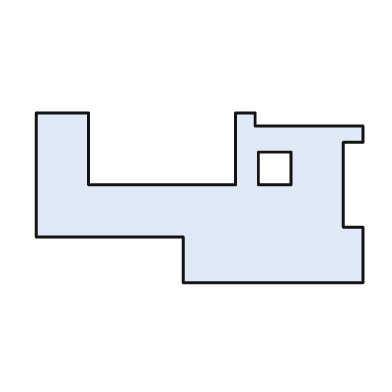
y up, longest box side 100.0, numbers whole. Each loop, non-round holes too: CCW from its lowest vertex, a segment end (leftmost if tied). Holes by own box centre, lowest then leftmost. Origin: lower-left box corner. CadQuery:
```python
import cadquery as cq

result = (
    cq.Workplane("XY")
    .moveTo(45.0, 0.0)
    .lineTo(100.0, 0.0)
    .lineTo(100.0, 17.0)
    .lineTo(94.0, 17.0)
    .lineTo(94.0, 43.0)
    .lineTo(100.0, 43.0)
    .lineTo(100.0, 48.0)
    .lineTo(67.0, 48.0)
    .lineTo(67.0, 52.0)
    .lineTo(61.0, 52.0)
    .lineTo(61.0, 30.0)
    .lineTo(16.0, 30.0)
    .lineTo(16.0, 52.0)
    .lineTo(0.0, 52.0)
    .lineTo(0.0, 14.0)
    .lineTo(45.0, 14.0)
    .close()
    .moveTo(68.0, 30.0)
    .lineTo(78.0, 30.0)
    .lineTo(78.0, 40.0)
    .lineTo(68.0, 40.0)
    .close()
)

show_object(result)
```